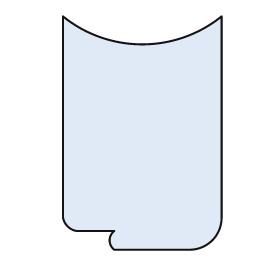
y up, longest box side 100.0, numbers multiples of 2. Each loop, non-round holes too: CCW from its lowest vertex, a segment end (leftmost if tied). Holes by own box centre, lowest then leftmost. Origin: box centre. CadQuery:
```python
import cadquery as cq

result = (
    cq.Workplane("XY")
    .moveTo(-12.0, -50.0)
    .lineTo(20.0, -50.0)
    .threePointArc((30.0, -46.0), (34.0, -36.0))
    .lineTo(34.0, 50.0)
    .threePointArc((0.0, 38.0), (-34.0, 50.0))
    .lineTo(-34.0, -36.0)
    .threePointArc((-32.0, -40.0), (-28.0, -42.0))
    .lineTo(-12.0, -42.0)
    .threePointArc((-14.0, -46.0), (-12.0, -50.0))
    .close()
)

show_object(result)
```